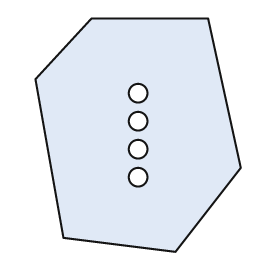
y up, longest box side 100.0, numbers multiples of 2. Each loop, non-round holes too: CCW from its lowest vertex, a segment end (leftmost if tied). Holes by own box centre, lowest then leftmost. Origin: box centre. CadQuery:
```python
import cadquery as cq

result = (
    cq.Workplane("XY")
    .moveTo(16.0, -50.0)
    .lineTo(44.0, -14.0)
    .lineTo(30.0, 50.0)
    .lineTo(-20.0, 50.0)
    .lineTo(-44.0, 24.0)
    .lineTo(-32.0, -44.0)
    .close()
    .moveTo(0.0, -18.0)
    .circle(4.0)
    .moveTo(0.0, -6.0)
    .circle(4.0)
    .moveTo(0.0, 6.0)
    .circle(4.0)
    .moveTo(0.0, 18.0)
    .circle(4.0)
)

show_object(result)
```